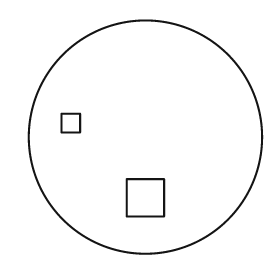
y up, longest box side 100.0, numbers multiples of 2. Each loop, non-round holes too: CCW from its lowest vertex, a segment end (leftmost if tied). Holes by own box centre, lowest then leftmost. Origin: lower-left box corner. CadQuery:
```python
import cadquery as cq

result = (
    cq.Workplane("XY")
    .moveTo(50.0, 50.0)
    .circle(50.0)
    .moveTo(42.0, 16.0)
    .lineTo(58.0, 16.0)
    .lineTo(58.0, 32.0)
    .lineTo(42.0, 32.0)
    .close()
    .moveTo(14.0, 52.0)
    .lineTo(22.0, 52.0)
    .lineTo(22.0, 60.0)
    .lineTo(14.0, 60.0)
    .close()
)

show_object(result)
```